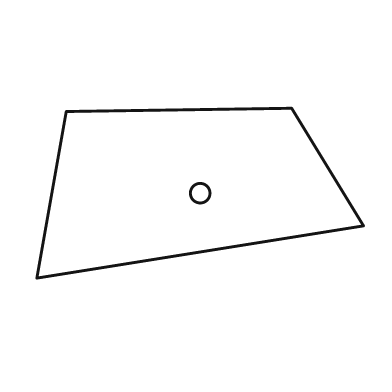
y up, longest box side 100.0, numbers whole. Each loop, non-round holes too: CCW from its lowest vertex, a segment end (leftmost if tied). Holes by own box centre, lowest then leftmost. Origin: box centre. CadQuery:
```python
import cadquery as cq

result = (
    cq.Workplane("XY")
    .moveTo(-50.0, -26.0)
    .lineTo(50.0, -10.0)
    .lineTo(28.0, 26.0)
    .lineTo(-41.0, 25.0)
    .close()
    .moveTo(0.0, 0.0)
    .circle(3.0)
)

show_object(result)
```